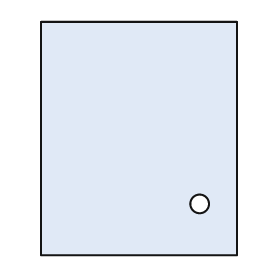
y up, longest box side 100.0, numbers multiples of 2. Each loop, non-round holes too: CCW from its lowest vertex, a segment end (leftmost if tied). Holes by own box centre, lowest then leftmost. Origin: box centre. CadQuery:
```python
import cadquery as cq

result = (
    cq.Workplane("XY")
    .moveTo(-42.0, -50.0)
    .lineTo(42.0, -50.0)
    .lineTo(42.0, 50.0)
    .lineTo(-42.0, 50.0)
    .close()
    .moveTo(26.0, -28.0)
    .circle(4.0)
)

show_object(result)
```